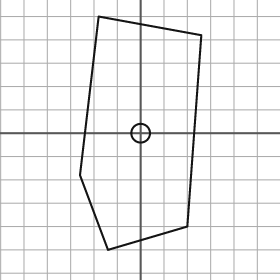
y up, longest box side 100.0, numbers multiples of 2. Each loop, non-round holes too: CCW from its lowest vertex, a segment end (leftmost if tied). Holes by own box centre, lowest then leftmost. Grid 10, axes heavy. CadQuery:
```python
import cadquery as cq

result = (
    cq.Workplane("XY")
    .moveTo(-14.0, -50.0)
    .lineTo(20.0, -40.0)
    .lineTo(26.0, 42.0)
    .lineTo(-18.0, 50.0)
    .lineTo(-26.0, -18.0)
    .close()
    .moveTo(0.0, 0.0)
    .circle(4.0)
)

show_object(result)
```